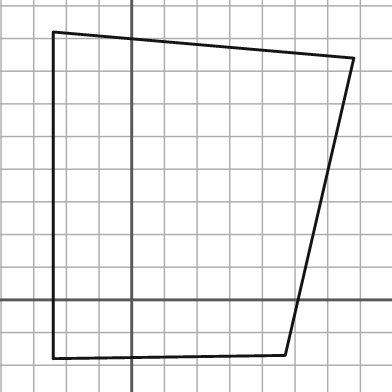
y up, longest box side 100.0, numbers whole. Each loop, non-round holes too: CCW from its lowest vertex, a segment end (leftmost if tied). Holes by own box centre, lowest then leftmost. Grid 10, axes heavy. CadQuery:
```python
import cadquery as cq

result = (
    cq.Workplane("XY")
    .moveTo(-24.0, -18.0)
    .lineTo(47.0, -17.0)
    .lineTo(68.0, 74.0)
    .lineTo(-24.0, 82.0)
    .close()
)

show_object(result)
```